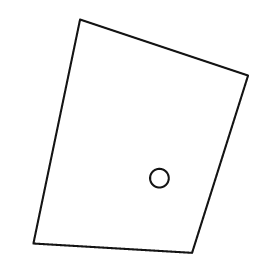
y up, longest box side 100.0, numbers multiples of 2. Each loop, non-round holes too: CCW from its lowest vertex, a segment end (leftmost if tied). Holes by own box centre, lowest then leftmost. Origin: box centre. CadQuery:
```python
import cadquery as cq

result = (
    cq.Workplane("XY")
    .moveTo(22.0, -50.0)
    .lineTo(46.0, 26.0)
    .lineTo(-26.0, 50.0)
    .lineTo(-46.0, -46.0)
    .close()
    .moveTo(8.0, -18.0)
    .circle(4.0)
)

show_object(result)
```